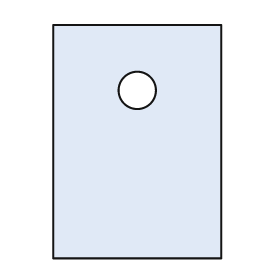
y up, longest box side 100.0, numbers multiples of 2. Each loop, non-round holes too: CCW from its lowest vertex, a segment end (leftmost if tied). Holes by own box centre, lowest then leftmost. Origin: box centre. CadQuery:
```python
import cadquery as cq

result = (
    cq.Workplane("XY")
    .moveTo(-36.0, -50.0)
    .lineTo(36.0, -50.0)
    .lineTo(36.0, 50.0)
    .lineTo(-36.0, 50.0)
    .close()
    .moveTo(0.0, 22.0)
    .circle(8.0)
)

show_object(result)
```